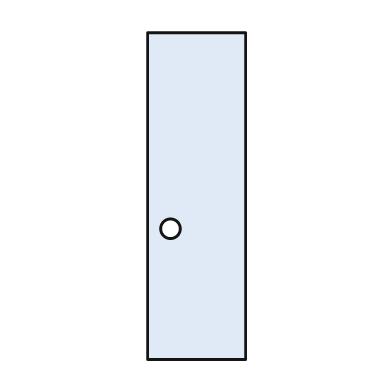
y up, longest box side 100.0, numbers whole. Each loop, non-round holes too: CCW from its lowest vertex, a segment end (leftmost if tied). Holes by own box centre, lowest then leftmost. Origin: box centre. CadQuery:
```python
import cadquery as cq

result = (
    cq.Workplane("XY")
    .moveTo(-15.0, -50.0)
    .lineTo(15.0, -50.0)
    .lineTo(15.0, 50.0)
    .lineTo(-15.0, 50.0)
    .close()
    .moveTo(-8.0, -10.0)
    .circle(3.0)
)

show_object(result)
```